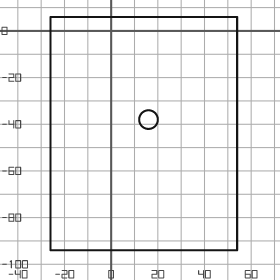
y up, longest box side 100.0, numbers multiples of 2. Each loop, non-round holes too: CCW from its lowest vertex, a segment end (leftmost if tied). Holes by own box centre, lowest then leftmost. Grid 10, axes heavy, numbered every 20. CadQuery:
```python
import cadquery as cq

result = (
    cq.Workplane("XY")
    .moveTo(-26.0, -94.0)
    .lineTo(54.0, -94.0)
    .lineTo(54.0, 6.0)
    .lineTo(-26.0, 6.0)
    .close()
    .moveTo(16.0, -38.0)
    .circle(4.0)
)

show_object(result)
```